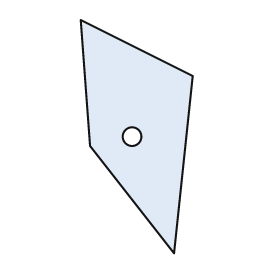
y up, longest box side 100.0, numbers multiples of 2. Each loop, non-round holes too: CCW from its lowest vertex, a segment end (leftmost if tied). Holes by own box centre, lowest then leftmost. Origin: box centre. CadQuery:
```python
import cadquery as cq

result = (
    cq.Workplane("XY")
    .moveTo(16.0, -50.0)
    .lineTo(24.0, 26.0)
    .lineTo(-24.0, 50.0)
    .lineTo(-20.0, -4.0)
    .close()
    .moveTo(-2.0, 0.0)
    .circle(4.0)
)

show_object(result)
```